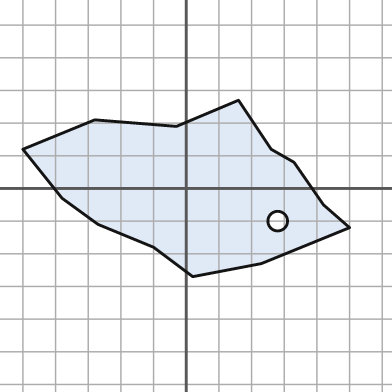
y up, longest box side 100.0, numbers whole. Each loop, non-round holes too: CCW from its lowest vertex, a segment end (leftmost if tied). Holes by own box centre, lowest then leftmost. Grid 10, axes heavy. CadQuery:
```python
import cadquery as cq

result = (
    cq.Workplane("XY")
    .moveTo(2.0, -27.0)
    .lineTo(23.0, -23.0)
    .lineTo(50.0, -12.0)
    .lineTo(42.0, -5.0)
    .lineTo(33.0, 8.0)
    .lineTo(26.0, 12.0)
    .lineTo(16.0, 27.0)
    .lineTo(-3.0, 19.0)
    .lineTo(-28.0, 21.0)
    .lineTo(-50.0, 12.0)
    .lineTo(-38.0, -3.0)
    .lineTo(-27.0, -11.0)
    .lineTo(-10.0, -18.0)
    .close()
    .moveTo(28.0, -10.0)
    .circle(3.0)
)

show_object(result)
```